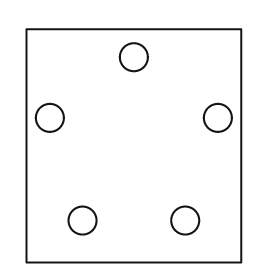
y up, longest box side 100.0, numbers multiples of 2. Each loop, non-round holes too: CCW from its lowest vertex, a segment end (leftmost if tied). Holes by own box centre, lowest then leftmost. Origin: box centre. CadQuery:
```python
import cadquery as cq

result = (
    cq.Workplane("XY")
    .moveTo(-46.0, -50.0)
    .lineTo(46.0, -50.0)
    .lineTo(46.0, 50.0)
    .lineTo(-46.0, 50.0)
    .close()
    .moveTo(-22.0, -32.0)
    .circle(6.0)
    .moveTo(22.0, -32.0)
    .circle(6.0)
    .moveTo(-36.0, 12.0)
    .circle(6.0)
    .moveTo(36.0, 12.0)
    .circle(6.0)
    .moveTo(0.0, 38.0)
    .circle(6.0)
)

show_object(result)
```